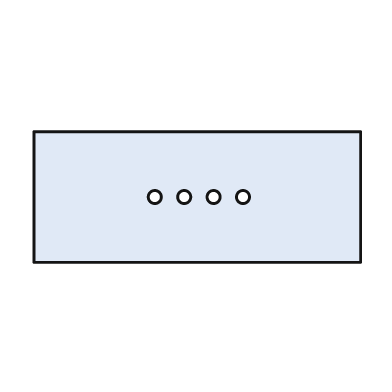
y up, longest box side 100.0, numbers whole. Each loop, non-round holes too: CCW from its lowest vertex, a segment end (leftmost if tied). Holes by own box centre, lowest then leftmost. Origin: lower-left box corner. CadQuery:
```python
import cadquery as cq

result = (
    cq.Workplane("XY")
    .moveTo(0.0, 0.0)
    .lineTo(100.0, 0.0)
    .lineTo(100.0, 40.0)
    .lineTo(0.0, 40.0)
    .close()
    .moveTo(37.0, 20.0)
    .circle(2.0)
    .moveTo(46.0, 20.0)
    .circle(2.0)
    .moveTo(55.0, 20.0)
    .circle(2.0)
    .moveTo(64.0, 20.0)
    .circle(2.0)
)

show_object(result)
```